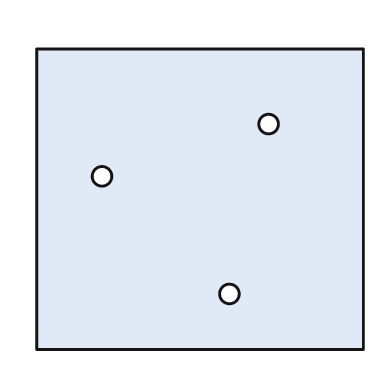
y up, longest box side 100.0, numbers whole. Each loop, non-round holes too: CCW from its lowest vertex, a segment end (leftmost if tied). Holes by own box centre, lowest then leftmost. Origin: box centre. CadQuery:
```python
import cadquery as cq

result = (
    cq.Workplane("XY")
    .moveTo(-50.0, -46.0)
    .lineTo(50.0, -46.0)
    .lineTo(50.0, 46.0)
    .lineTo(-50.0, 46.0)
    .close()
    .moveTo(9.0, -29.0)
    .circle(3.0)
    .moveTo(-30.0, 7.0)
    .circle(3.0)
    .moveTo(21.0, 23.0)
    .circle(3.0)
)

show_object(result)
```